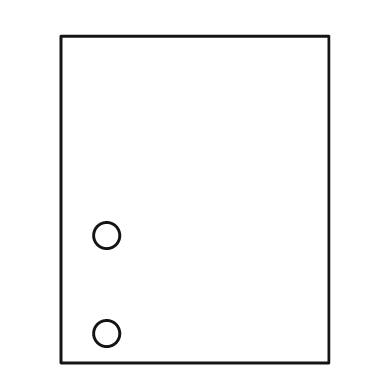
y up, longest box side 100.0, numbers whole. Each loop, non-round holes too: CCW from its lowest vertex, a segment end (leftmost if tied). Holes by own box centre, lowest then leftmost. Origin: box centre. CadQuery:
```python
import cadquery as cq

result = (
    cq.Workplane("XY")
    .moveTo(-41.0, -50.0)
    .lineTo(41.0, -50.0)
    .lineTo(41.0, 50.0)
    .lineTo(-41.0, 50.0)
    .close()
    .moveTo(-27.0, -41.0)
    .circle(4.0)
    .moveTo(-27.0, -11.0)
    .circle(4.0)
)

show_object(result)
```